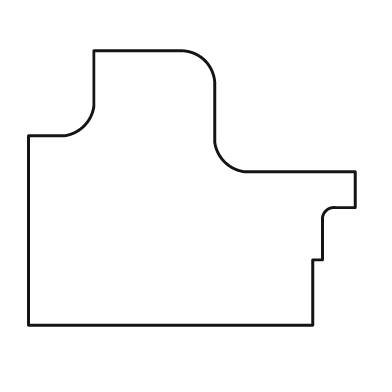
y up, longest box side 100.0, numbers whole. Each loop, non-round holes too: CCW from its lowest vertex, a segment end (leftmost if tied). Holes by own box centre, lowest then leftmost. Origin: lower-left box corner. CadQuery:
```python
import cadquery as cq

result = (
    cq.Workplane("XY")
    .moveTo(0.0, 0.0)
    .lineTo(87.0, 0.0)
    .lineTo(87.0, 20.0)
    .lineTo(90.0, 20.0)
    .lineTo(90.0, 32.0)
    .threePointArc((91.0, 35.0), (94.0, 36.0))
    .lineTo(100.0, 36.0)
    .lineTo(100.0, 47.0)
    .lineTo(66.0, 47.0)
    .threePointArc((60.0, 50.0), (57.0, 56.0))
    .lineTo(57.0, 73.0)
    .threePointArc((54.0, 81.0), (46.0, 84.0))
    .lineTo(20.0, 84.0)
    .lineTo(20.0, 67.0)
    .threePointArc((17.0, 61.0), (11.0, 58.0))
    .lineTo(0.0, 58.0)
    .close()
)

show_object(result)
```